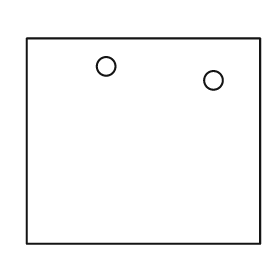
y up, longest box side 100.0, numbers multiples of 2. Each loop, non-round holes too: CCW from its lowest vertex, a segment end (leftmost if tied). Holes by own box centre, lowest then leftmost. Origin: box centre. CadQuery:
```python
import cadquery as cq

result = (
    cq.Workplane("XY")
    .moveTo(-50.0, -44.0)
    .lineTo(50.0, -44.0)
    .lineTo(50.0, 44.0)
    .lineTo(-50.0, 44.0)
    .close()
    .moveTo(30.0, 26.0)
    .circle(4.0)
    .moveTo(-16.0, 32.0)
    .circle(4.0)
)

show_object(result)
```